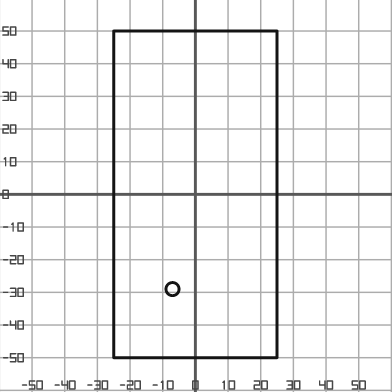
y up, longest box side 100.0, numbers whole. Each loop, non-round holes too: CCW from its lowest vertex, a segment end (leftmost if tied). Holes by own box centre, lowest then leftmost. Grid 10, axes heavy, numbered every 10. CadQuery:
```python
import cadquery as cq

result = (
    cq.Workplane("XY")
    .moveTo(-25.0, -50.0)
    .lineTo(25.0, -50.0)
    .lineTo(25.0, 50.0)
    .lineTo(-25.0, 50.0)
    .close()
    .moveTo(-7.0, -29.0)
    .circle(2.0)
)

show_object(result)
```